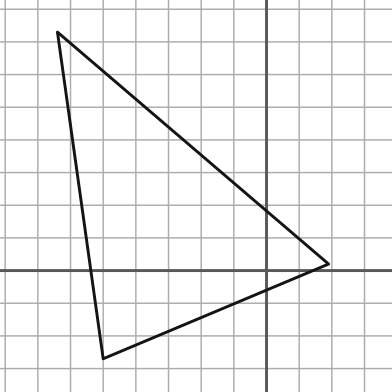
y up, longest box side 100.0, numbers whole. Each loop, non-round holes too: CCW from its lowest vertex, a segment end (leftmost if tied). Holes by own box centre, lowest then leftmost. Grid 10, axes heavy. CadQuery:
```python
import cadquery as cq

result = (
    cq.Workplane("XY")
    .moveTo(-50.0, -27.0)
    .lineTo(19.0, 2.0)
    .lineTo(-64.0, 73.0)
    .close()
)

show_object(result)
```